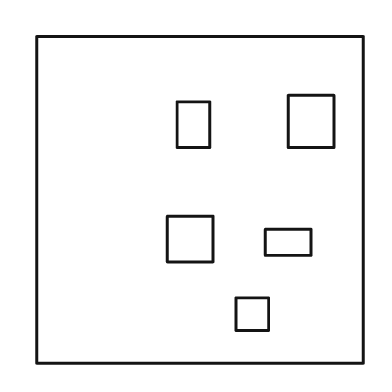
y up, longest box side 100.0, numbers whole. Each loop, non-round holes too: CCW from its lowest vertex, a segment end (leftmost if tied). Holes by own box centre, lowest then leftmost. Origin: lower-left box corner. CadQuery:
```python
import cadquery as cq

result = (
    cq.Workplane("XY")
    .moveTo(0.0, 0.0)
    .lineTo(100.0, 0.0)
    .lineTo(100.0, 100.0)
    .lineTo(0.0, 100.0)
    .close()
    .moveTo(61.0, 10.0)
    .lineTo(71.0, 10.0)
    .lineTo(71.0, 20.0)
    .lineTo(61.0, 20.0)
    .close()
    .moveTo(70.0, 33.0)
    .lineTo(84.0, 33.0)
    .lineTo(84.0, 41.0)
    .lineTo(70.0, 41.0)
    .close()
    .moveTo(40.0, 31.0)
    .lineTo(54.0, 31.0)
    .lineTo(54.0, 45.0)
    .lineTo(40.0, 45.0)
    .close()
    .moveTo(43.0, 66.0)
    .lineTo(53.0, 66.0)
    .lineTo(53.0, 80.0)
    .lineTo(43.0, 80.0)
    .close()
    .moveTo(77.0, 66.0)
    .lineTo(91.0, 66.0)
    .lineTo(91.0, 82.0)
    .lineTo(77.0, 82.0)
    .close()
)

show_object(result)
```